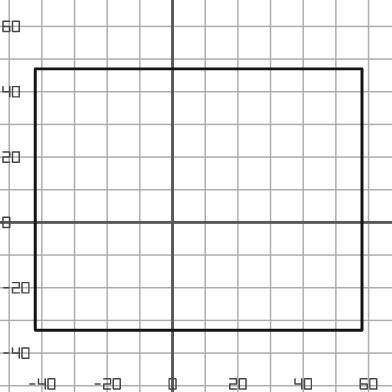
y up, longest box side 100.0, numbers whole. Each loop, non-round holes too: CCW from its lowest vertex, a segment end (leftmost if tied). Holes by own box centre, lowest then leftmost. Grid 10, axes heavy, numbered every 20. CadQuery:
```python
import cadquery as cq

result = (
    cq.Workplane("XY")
    .moveTo(-42.0, -33.0)
    .lineTo(58.0, -33.0)
    .lineTo(58.0, 47.0)
    .lineTo(-42.0, 47.0)
    .close()
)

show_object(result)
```